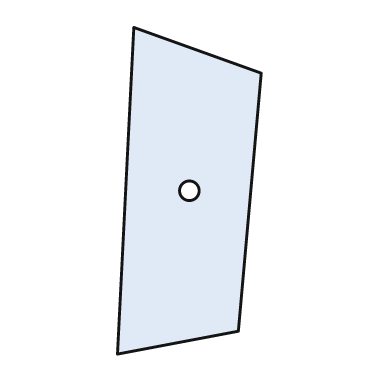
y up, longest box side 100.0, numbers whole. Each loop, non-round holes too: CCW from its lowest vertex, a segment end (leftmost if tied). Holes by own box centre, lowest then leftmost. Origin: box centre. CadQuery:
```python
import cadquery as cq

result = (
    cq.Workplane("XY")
    .moveTo(-22.0, -50.0)
    .lineTo(15.0, -43.0)
    .lineTo(22.0, 36.0)
    .lineTo(-17.0, 50.0)
    .close()
    .moveTo(0.0, 0.0)
    .circle(3.0)
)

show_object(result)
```